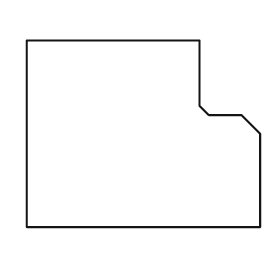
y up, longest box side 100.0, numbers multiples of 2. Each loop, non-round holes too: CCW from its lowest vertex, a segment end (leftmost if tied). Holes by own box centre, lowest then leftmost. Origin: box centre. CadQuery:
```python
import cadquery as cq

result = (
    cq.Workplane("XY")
    .moveTo(-50.0, -40.0)
    .lineTo(50.0, -40.0)
    .lineTo(50.0, 0.0)
    .lineTo(42.0, 8.0)
    .lineTo(28.0, 8.0)
    .lineTo(24.0, 12.0)
    .lineTo(24.0, 40.0)
    .lineTo(-50.0, 40.0)
    .close()
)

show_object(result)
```